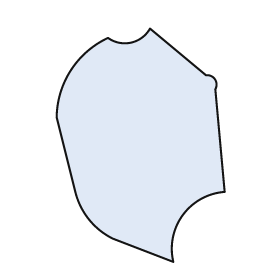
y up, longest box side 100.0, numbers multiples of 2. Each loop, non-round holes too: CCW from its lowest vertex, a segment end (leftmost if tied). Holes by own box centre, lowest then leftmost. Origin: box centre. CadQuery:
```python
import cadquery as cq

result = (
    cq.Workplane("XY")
    .moveTo(14.0, -50.0)
    .threePointArc((18.0, -30.0), (36.0, -20.0))
    .lineTo(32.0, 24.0)
    .threePointArc((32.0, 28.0), (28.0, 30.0))
    .lineTo(4.0, 50.0)
    .threePointArc((-4.0, 44.0), (-14.0, 46.0))
    .threePointArc((-30.0, 32.0), (-36.0, 12.0))
    .lineTo(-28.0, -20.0)
    .threePointArc((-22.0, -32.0), (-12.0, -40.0))
    .close()
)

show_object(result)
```